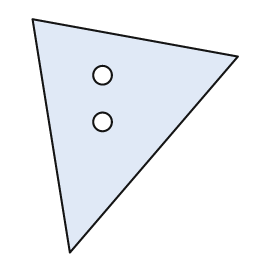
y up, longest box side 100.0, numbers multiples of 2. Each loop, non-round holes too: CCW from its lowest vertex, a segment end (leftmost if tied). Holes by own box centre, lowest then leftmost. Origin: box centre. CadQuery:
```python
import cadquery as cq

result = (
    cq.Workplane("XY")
    .moveTo(-28.0, -50.0)
    .lineTo(44.0, 34.0)
    .lineTo(-44.0, 50.0)
    .close()
    .moveTo(-14.0, 6.0)
    .circle(4.0)
    .moveTo(-14.0, 26.0)
    .circle(4.0)
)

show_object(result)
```